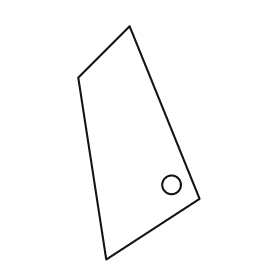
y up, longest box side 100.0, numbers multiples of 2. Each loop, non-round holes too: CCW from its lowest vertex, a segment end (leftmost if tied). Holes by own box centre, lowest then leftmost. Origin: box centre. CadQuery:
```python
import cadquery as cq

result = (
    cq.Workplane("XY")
    .moveTo(-14.0, -50.0)
    .lineTo(26.0, -24.0)
    .lineTo(-4.0, 50.0)
    .lineTo(-26.0, 28.0)
    .close()
    .moveTo(14.0, -18.0)
    .circle(4.0)
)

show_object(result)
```